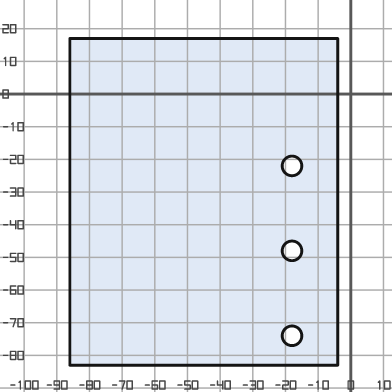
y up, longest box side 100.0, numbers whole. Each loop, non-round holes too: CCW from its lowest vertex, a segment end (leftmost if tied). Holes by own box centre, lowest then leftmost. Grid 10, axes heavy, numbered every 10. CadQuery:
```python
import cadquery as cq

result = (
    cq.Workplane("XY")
    .moveTo(-86.0, -83.0)
    .lineTo(-4.0, -83.0)
    .lineTo(-4.0, 17.0)
    .lineTo(-86.0, 17.0)
    .close()
    .moveTo(-18.0, -74.0)
    .circle(3.0)
    .moveTo(-18.0, -48.0)
    .circle(3.0)
    .moveTo(-18.0, -22.0)
    .circle(3.0)
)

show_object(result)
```